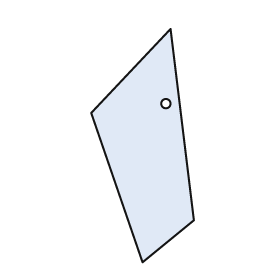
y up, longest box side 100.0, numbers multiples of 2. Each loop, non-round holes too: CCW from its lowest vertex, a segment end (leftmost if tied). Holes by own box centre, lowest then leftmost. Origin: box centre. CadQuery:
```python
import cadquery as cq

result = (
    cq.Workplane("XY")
    .moveTo(0.0, -50.0)
    .lineTo(22.0, -32.0)
    .lineTo(12.0, 50.0)
    .lineTo(-22.0, 14.0)
    .close()
    .moveTo(10.0, 18.0)
    .circle(2.0)
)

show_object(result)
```